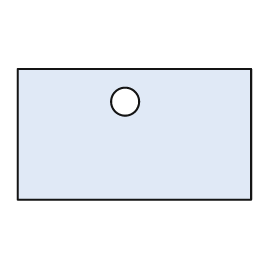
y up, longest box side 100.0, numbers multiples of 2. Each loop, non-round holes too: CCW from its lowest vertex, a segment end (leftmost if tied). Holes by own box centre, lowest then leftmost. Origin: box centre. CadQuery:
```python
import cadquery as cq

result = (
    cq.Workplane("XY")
    .moveTo(-50.0, -28.0)
    .lineTo(50.0, -28.0)
    .lineTo(50.0, 28.0)
    .lineTo(-50.0, 28.0)
    .close()
    .moveTo(-4.0, 14.0)
    .circle(6.0)
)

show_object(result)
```